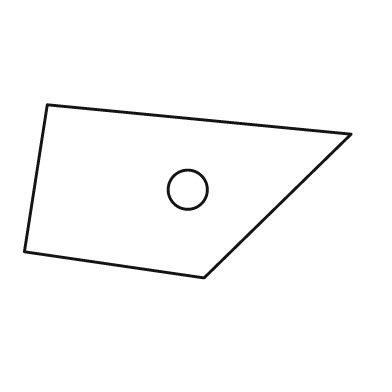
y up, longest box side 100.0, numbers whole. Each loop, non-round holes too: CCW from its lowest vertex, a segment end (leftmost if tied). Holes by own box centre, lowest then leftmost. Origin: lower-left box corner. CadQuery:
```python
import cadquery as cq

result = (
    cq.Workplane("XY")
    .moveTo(55.0, 0.0)
    .lineTo(100.0, 44.0)
    .lineTo(7.0, 53.0)
    .lineTo(0.0, 8.0)
    .close()
    .moveTo(50.0, 27.0)
    .circle(6.0)
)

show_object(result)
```